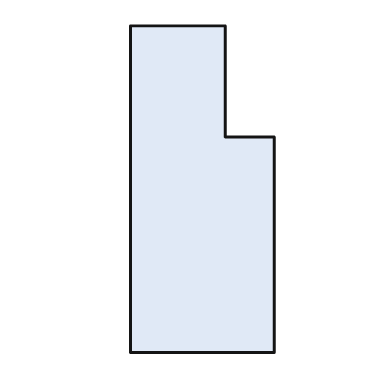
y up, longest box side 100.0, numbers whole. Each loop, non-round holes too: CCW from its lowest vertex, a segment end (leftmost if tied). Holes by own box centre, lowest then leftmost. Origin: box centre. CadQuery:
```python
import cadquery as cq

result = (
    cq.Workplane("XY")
    .moveTo(-22.0, -50.0)
    .lineTo(22.0, -50.0)
    .lineTo(22.0, 16.0)
    .lineTo(7.0, 16.0)
    .lineTo(7.0, 50.0)
    .lineTo(-22.0, 50.0)
    .close()
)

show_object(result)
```